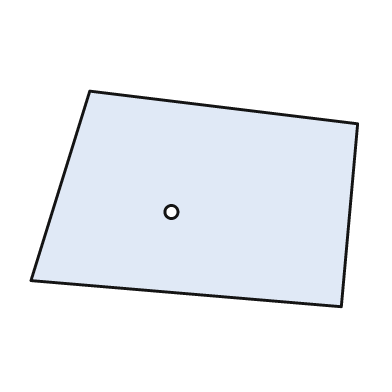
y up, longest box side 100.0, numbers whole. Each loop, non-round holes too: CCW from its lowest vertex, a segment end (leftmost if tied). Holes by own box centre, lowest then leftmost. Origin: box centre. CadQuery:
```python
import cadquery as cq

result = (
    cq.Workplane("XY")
    .moveTo(45.0, -33.0)
    .lineTo(50.0, 23.0)
    .lineTo(-32.0, 33.0)
    .lineTo(-50.0, -25.0)
    .close()
    .moveTo(-7.0, -4.0)
    .circle(2.0)
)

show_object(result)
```